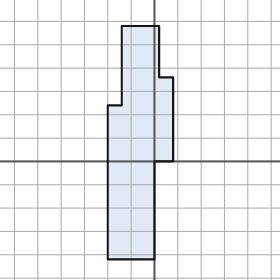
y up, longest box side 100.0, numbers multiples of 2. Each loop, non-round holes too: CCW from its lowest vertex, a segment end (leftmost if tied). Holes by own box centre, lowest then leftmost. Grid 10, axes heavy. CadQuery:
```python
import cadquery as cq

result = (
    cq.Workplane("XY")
    .moveTo(-20.0, -42.0)
    .lineTo(0.0, -42.0)
    .lineTo(0.0, 0.0)
    .lineTo(8.0, 0.0)
    .lineTo(8.0, 36.0)
    .lineTo(2.0, 36.0)
    .lineTo(2.0, 58.0)
    .lineTo(-14.0, 58.0)
    .lineTo(-14.0, 24.0)
    .lineTo(-20.0, 24.0)
    .close()
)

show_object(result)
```